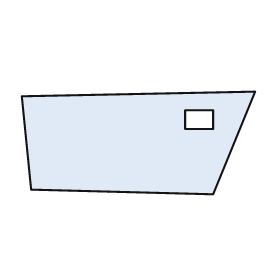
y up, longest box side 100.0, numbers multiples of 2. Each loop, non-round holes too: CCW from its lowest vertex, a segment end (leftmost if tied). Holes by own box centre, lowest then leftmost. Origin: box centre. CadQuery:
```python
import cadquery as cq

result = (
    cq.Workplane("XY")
    .moveTo(32.0, -22.0)
    .lineTo(50.0, 22.0)
    .lineTo(-50.0, 20.0)
    .lineTo(-46.0, -20.0)
    .close()
    .moveTo(20.0, 6.0)
    .lineTo(32.0, 6.0)
    .lineTo(32.0, 14.0)
    .lineTo(20.0, 14.0)
    .close()
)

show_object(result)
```